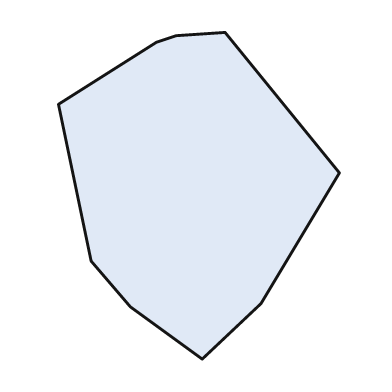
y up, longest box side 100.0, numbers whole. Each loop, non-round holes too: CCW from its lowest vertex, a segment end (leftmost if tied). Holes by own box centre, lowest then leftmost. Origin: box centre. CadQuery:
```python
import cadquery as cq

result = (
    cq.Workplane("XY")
    .moveTo(1.0, -50.0)
    .lineTo(19.0, -33.0)
    .lineTo(43.0, 7.0)
    .lineTo(8.0, 50.0)
    .lineTo(-7.0, 49.0)
    .lineTo(-13.0, 47.0)
    .lineTo(-43.0, 28.0)
    .lineTo(-33.0, -20.0)
    .lineTo(-21.0, -34.0)
    .close()
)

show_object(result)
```